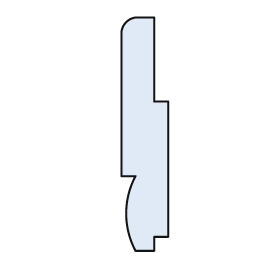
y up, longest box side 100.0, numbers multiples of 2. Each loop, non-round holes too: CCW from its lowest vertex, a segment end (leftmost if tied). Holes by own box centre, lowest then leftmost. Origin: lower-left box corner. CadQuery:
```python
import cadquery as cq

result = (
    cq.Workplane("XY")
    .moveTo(6.0, 0.0)
    .lineTo(14.0, 0.0)
    .lineTo(14.0, 6.0)
    .lineTo(20.0, 6.0)
    .lineTo(20.0, 64.0)
    .lineTo(14.0, 64.0)
    .lineTo(14.0, 100.0)
    .lineTo(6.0, 100.0)
    .threePointArc((2.0, 98.0), (0.0, 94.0))
    .lineTo(0.0, 32.0)
    .lineTo(6.0, 32.0)
    .threePointArc((2.0, 16.0), (6.0, 0.0))
    .close()
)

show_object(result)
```